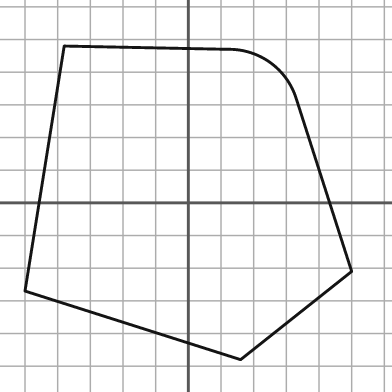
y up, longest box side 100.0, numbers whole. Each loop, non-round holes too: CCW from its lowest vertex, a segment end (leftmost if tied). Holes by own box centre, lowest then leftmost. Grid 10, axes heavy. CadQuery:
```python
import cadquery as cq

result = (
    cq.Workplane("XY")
    .moveTo(16.0, -48.0)
    .lineTo(50.0, -21.0)
    .lineTo(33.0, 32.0)
    .threePointArc((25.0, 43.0), (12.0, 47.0))
    .lineTo(-38.0, 48.0)
    .lineTo(-50.0, -27.0)
    .close()
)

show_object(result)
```